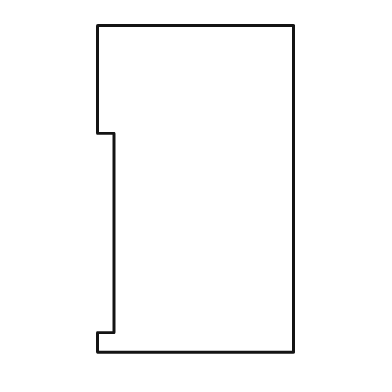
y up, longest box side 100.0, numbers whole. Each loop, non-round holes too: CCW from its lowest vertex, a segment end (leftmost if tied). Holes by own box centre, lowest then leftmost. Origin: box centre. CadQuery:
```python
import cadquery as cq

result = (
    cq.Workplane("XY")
    .moveTo(-30.0, -50.0)
    .lineTo(30.0, -50.0)
    .lineTo(30.0, 50.0)
    .lineTo(-30.0, 50.0)
    .lineTo(-30.0, 17.0)
    .lineTo(-25.0, 17.0)
    .lineTo(-25.0, -44.0)
    .lineTo(-30.0, -44.0)
    .close()
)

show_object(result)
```